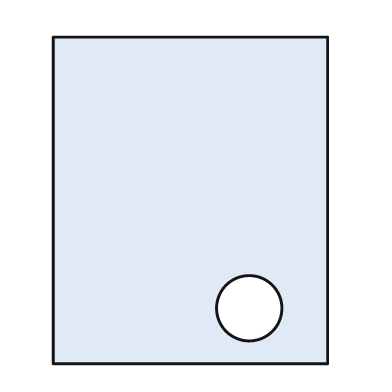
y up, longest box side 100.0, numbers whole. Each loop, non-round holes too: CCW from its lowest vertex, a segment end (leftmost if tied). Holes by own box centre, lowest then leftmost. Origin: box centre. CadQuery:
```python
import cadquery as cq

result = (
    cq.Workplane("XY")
    .moveTo(-42.0, -50.0)
    .lineTo(42.0, -50.0)
    .lineTo(42.0, 50.0)
    .lineTo(-42.0, 50.0)
    .close()
    .moveTo(18.0, -33.0)
    .circle(10.0)
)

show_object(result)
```